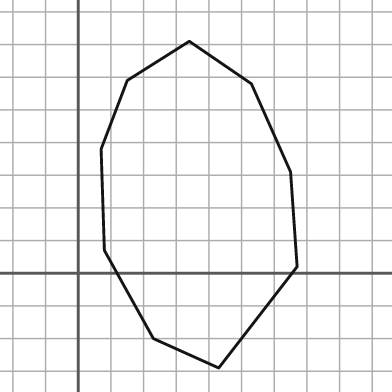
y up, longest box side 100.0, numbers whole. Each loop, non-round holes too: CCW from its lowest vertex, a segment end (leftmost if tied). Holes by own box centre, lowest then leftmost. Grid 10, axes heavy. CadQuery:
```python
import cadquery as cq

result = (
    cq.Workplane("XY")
    .moveTo(43.0, -29.0)
    .lineTo(67.0, 2.0)
    .lineTo(65.0, 31.0)
    .lineTo(53.0, 58.0)
    .lineTo(34.0, 71.0)
    .lineTo(15.0, 59.0)
    .lineTo(7.0, 38.0)
    .lineTo(8.0, 7.0)
    .lineTo(23.0, -20.0)
    .close()
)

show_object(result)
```